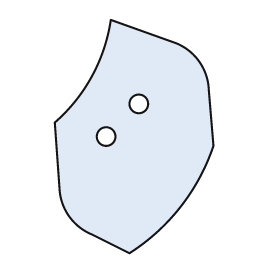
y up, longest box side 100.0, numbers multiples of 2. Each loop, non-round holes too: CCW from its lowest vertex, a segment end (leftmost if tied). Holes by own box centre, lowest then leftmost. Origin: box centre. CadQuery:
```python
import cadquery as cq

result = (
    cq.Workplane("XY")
    .moveTo(-2.0, -50.0)
    .threePointArc((20.0, -30.0), (34.0, -4.0))
    .lineTo(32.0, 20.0)
    .threePointArc((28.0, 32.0), (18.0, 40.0))
    .lineTo(-10.0, 50.0)
    .threePointArc((-18.0, 26.0), (-34.0, 6.0))
    .lineTo(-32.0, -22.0)
    .threePointArc((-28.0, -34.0), (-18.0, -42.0))
    .close()
    .moveTo(-12.0, 0.0)
    .circle(4.0)
    .moveTo(2.0, 14.0)
    .circle(4.0)
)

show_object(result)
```